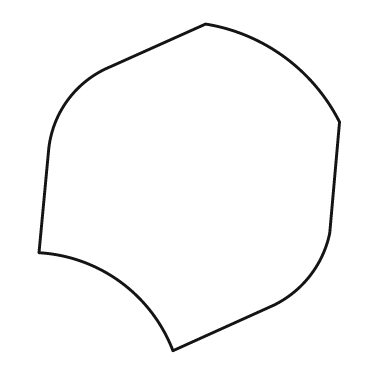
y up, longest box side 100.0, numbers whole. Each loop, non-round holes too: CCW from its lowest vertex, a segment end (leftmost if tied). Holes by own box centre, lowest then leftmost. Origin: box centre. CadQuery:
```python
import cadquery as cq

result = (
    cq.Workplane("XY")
    .moveTo(-5.0, -50.0)
    .lineTo(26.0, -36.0)
    .threePointArc((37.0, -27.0), (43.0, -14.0))
    .lineTo(46.0, 20.0)
    .threePointArc((29.0, 40.0), (5.0, 50.0))
    .lineTo(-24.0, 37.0)
    .threePointArc((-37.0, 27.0), (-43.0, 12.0))
    .lineTo(-46.0, -20.0)
    .threePointArc((-21.0, -29.0), (-5.0, -50.0))
    .close()
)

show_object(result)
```